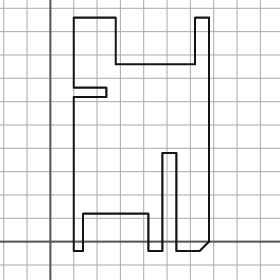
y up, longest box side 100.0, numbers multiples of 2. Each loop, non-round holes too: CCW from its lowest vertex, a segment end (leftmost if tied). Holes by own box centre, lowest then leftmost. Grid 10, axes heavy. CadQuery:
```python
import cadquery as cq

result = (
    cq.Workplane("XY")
    .moveTo(10.0, -4.0)
    .lineTo(14.0, -4.0)
    .lineTo(14.0, 12.0)
    .lineTo(42.0, 12.0)
    .lineTo(42.0, -4.0)
    .lineTo(48.0, -4.0)
    .lineTo(48.0, 38.0)
    .lineTo(54.0, 38.0)
    .lineTo(54.0, -4.0)
    .lineTo(64.0, -4.0)
    .lineTo(68.0, 0.0)
    .lineTo(68.0, 96.0)
    .lineTo(62.0, 96.0)
    .lineTo(62.0, 76.0)
    .lineTo(28.0, 76.0)
    .lineTo(28.0, 96.0)
    .lineTo(10.0, 96.0)
    .lineTo(10.0, 66.0)
    .lineTo(24.0, 66.0)
    .lineTo(24.0, 62.0)
    .lineTo(10.0, 62.0)
    .close()
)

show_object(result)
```